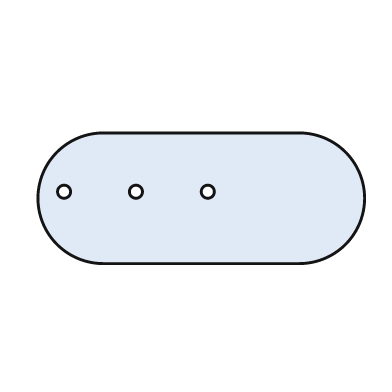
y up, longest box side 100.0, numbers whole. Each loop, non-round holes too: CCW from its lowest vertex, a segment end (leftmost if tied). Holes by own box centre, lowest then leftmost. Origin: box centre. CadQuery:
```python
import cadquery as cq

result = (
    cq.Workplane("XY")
    .moveTo(-30.0, -20.0)
    .lineTo(30.0, -20.0)
    .threePointArc((50.0, 0.0), (30.0, 20.0))
    .lineTo(-30.0, 20.0)
    .threePointArc((-50.0, 0.0), (-30.0, -20.0))
    .close()
    .moveTo(-42.0, 2.0)
    .circle(2.0)
    .moveTo(-20.0, 2.0)
    .circle(2.0)
    .moveTo(2.0, 2.0)
    .circle(2.0)
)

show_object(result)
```